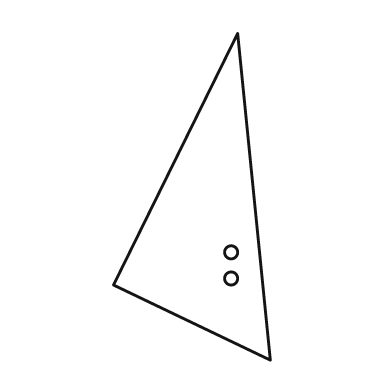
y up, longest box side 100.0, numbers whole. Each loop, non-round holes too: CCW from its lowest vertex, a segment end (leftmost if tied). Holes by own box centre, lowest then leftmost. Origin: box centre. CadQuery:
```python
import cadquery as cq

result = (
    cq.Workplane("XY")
    .moveTo(24.0, -50.0)
    .lineTo(14.0, 50.0)
    .lineTo(-24.0, -27.0)
    .close()
    .moveTo(12.0, -25.0)
    .circle(2.0)
    .moveTo(12.0, -17.0)
    .circle(2.0)
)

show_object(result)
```